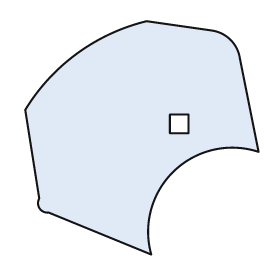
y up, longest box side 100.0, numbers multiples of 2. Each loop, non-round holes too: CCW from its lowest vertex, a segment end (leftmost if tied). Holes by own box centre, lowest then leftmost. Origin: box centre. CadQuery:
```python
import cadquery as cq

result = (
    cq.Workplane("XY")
    .moveTo(4.0, -50.0)
    .threePointArc((14.0, -14.0), (50.0, -6.0))
    .lineTo(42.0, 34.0)
    .threePointArc((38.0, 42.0), (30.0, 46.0))
    .lineTo(2.0, 50.0)
    .threePointArc((-28.0, 36.0), (-50.0, 12.0))
    .lineTo(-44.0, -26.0)
    .threePointArc((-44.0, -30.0), (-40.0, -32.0))
    .close()
    .moveTo(12.0, 2.0)
    .lineTo(20.0, 2.0)
    .lineTo(20.0, 10.0)
    .lineTo(12.0, 10.0)
    .close()
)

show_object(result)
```